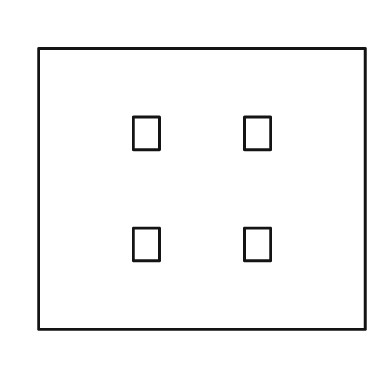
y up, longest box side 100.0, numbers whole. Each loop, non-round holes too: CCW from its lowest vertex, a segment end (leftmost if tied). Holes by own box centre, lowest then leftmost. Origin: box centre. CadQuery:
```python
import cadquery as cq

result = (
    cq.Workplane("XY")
    .moveTo(-50.0, -43.0)
    .lineTo(50.0, -43.0)
    .lineTo(50.0, 43.0)
    .lineTo(-50.0, 43.0)
    .close()
    .moveTo(-21.0, -22.0)
    .lineTo(-13.0, -22.0)
    .lineTo(-13.0, -12.0)
    .lineTo(-21.0, -12.0)
    .close()
    .moveTo(13.0, -22.0)
    .lineTo(21.0, -22.0)
    .lineTo(21.0, -12.0)
    .lineTo(13.0, -12.0)
    .close()
    .moveTo(-21.0, 12.0)
    .lineTo(-13.0, 12.0)
    .lineTo(-13.0, 22.0)
    .lineTo(-21.0, 22.0)
    .close()
    .moveTo(13.0, 12.0)
    .lineTo(21.0, 12.0)
    .lineTo(21.0, 22.0)
    .lineTo(13.0, 22.0)
    .close()
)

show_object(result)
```